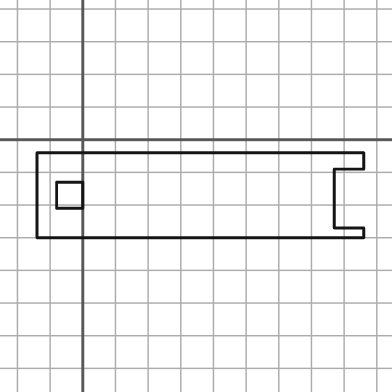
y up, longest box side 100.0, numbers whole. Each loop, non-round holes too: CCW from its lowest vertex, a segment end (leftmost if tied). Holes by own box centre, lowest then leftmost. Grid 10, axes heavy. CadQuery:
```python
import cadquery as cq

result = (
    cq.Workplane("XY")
    .moveTo(-14.0, -30.0)
    .lineTo(86.0, -30.0)
    .lineTo(86.0, -27.0)
    .lineTo(77.0, -27.0)
    .lineTo(77.0, -9.0)
    .lineTo(86.0, -9.0)
    .lineTo(86.0, -4.0)
    .lineTo(-14.0, -4.0)
    .close()
    .moveTo(-8.0, -21.0)
    .lineTo(0.0, -21.0)
    .lineTo(0.0, -13.0)
    .lineTo(-8.0, -13.0)
    .close()
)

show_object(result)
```